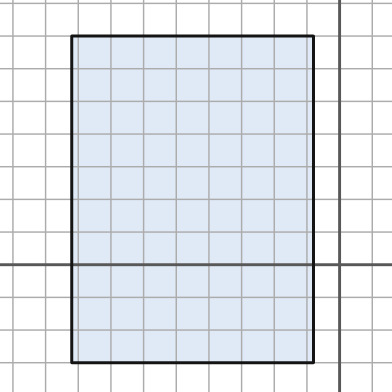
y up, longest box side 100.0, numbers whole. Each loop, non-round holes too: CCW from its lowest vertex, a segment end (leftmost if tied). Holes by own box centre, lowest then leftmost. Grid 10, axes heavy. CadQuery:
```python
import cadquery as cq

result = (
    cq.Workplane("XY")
    .moveTo(-82.0, -30.0)
    .lineTo(-8.0, -30.0)
    .lineTo(-8.0, 70.0)
    .lineTo(-82.0, 70.0)
    .close()
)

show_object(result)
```